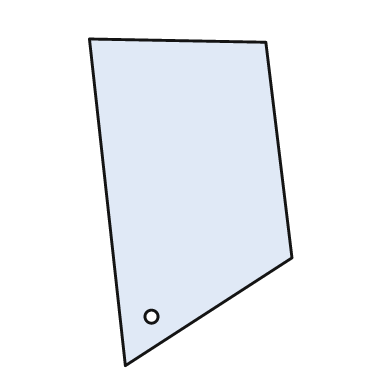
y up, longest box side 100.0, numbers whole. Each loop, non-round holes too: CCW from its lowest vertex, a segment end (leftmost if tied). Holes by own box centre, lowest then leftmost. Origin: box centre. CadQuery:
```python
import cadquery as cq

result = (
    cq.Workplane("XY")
    .moveTo(-20.0, -50.0)
    .lineTo(31.0, -17.0)
    .lineTo(23.0, 49.0)
    .lineTo(-31.0, 50.0)
    .close()
    .moveTo(-12.0, -35.0)
    .circle(2.0)
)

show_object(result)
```